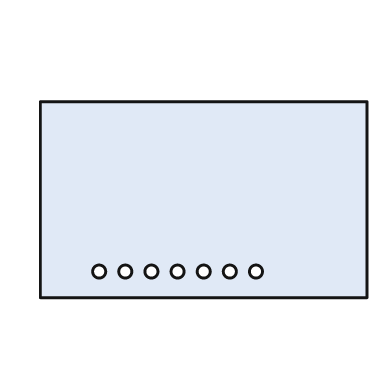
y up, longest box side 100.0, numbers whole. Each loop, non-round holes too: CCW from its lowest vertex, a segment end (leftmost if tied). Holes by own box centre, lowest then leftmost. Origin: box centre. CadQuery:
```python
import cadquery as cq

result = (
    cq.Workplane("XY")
    .moveTo(-50.0, -30.0)
    .lineTo(50.0, -30.0)
    .lineTo(50.0, 30.0)
    .lineTo(-50.0, 30.0)
    .close()
    .moveTo(-32.0, -22.0)
    .circle(2.0)
    .moveTo(-24.0, -22.0)
    .circle(2.0)
    .moveTo(-16.0, -22.0)
    .circle(2.0)
    .moveTo(-8.0, -22.0)
    .circle(2.0)
    .moveTo(0.0, -22.0)
    .circle(2.0)
    .moveTo(8.0, -22.0)
    .circle(2.0)
    .moveTo(16.0, -22.0)
    .circle(2.0)
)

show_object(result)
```